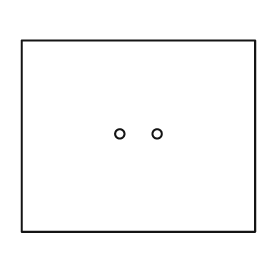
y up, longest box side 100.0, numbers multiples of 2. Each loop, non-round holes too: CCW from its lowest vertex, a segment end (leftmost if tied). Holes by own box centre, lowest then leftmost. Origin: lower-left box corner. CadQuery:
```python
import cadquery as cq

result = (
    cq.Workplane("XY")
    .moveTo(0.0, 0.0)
    .lineTo(100.0, 0.0)
    .lineTo(100.0, 82.0)
    .lineTo(0.0, 82.0)
    .close()
    .moveTo(42.0, 42.0)
    .circle(2.0)
    .moveTo(58.0, 42.0)
    .circle(2.0)
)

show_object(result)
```